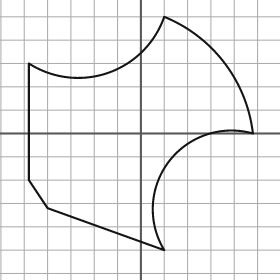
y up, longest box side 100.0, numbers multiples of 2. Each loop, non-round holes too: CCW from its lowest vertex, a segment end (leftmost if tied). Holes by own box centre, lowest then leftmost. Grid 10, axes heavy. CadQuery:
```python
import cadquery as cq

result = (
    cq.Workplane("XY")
    .moveTo(10.0, -50.0)
    .threePointArc((12.0, -12.0), (48.0, 0.0))
    .threePointArc((36.0, 30.0), (10.0, 50.0))
    .threePointArc((-14.0, 26.0), (-48.0, 30.0))
    .lineTo(-48.0, -20.0)
    .lineTo(-40.0, -32.0)
    .close()
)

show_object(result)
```